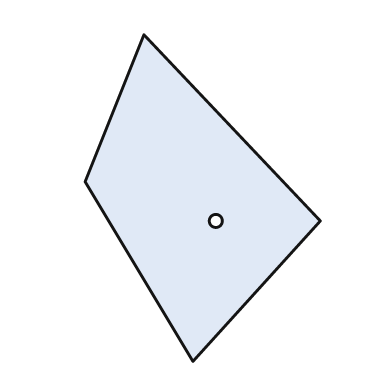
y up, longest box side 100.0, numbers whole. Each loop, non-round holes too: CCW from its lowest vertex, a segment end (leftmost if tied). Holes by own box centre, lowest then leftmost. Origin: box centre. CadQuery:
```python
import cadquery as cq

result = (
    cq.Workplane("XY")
    .moveTo(-3.0, -50.0)
    .lineTo(36.0, -7.0)
    .lineTo(-18.0, 50.0)
    .lineTo(-36.0, 5.0)
    .close()
    .moveTo(4.0, -7.0)
    .circle(2.0)
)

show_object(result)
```